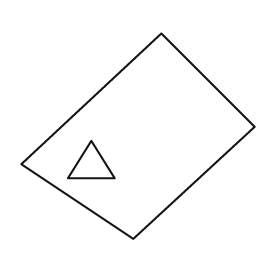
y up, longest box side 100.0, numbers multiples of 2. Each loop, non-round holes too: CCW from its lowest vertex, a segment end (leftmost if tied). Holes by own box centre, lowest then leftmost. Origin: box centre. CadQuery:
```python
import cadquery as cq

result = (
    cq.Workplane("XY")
    .moveTo(-2.0, -44.0)
    .lineTo(50.0, 4.0)
    .lineTo(10.0, 44.0)
    .lineTo(-50.0, -12.0)
    .close()
    .moveTo(-30.0, -18.0)
    .lineTo(-10.0, -18.0)
    .lineTo(-20.0, -2.0)
    .close()
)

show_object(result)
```